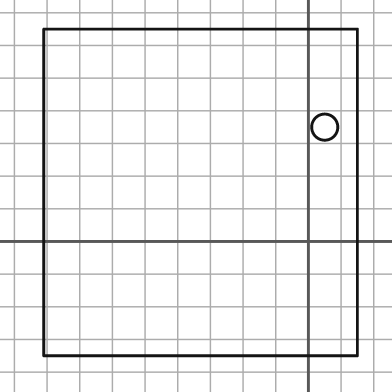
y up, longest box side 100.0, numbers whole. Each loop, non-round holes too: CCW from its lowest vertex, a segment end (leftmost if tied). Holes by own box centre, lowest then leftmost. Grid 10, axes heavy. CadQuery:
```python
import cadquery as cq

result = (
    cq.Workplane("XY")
    .moveTo(-81.0, -35.0)
    .lineTo(15.0, -35.0)
    .lineTo(15.0, 65.0)
    .lineTo(-81.0, 65.0)
    .close()
    .moveTo(5.0, 35.0)
    .circle(4.0)
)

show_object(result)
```